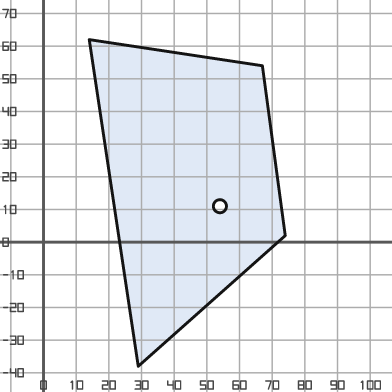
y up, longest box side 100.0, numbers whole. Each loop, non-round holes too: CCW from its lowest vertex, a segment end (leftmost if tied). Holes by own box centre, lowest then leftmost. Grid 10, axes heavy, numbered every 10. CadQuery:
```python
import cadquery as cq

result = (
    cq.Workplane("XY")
    .moveTo(29.0, -38.0)
    .lineTo(74.0, 2.0)
    .lineTo(67.0, 54.0)
    .lineTo(14.0, 62.0)
    .close()
    .moveTo(54.0, 11.0)
    .circle(2.0)
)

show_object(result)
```